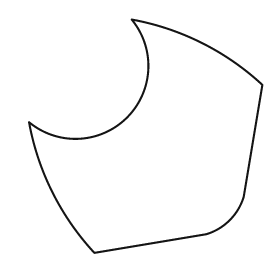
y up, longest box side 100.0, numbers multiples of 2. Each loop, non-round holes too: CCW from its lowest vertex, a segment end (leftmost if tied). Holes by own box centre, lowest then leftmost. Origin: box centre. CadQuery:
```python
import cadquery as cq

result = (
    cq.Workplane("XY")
    .moveTo(-22.0, -50.0)
    .lineTo(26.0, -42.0)
    .threePointArc((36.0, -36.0), (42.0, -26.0))
    .lineTo(50.0, 22.0)
    .threePointArc((24.0, 40.0), (-6.0, 50.0))
    .threePointArc((-8.0, 8.0), (-50.0, 6.0))
    .threePointArc((-40.0, -24.0), (-22.0, -50.0))
    .close()
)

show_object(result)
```